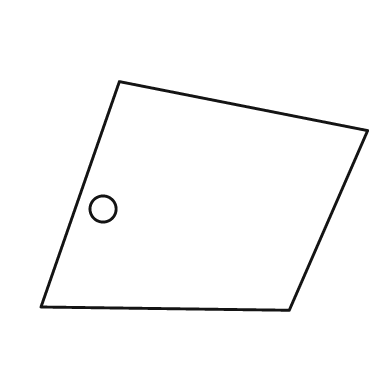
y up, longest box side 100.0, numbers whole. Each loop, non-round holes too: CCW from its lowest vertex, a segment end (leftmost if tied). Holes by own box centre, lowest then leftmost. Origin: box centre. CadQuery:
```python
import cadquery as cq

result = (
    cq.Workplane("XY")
    .moveTo(26.0, -35.0)
    .lineTo(50.0, 20.0)
    .lineTo(-26.0, 35.0)
    .lineTo(-50.0, -34.0)
    .close()
    .moveTo(-31.0, -4.0)
    .circle(4.0)
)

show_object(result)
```